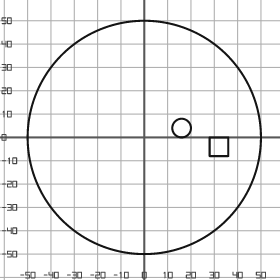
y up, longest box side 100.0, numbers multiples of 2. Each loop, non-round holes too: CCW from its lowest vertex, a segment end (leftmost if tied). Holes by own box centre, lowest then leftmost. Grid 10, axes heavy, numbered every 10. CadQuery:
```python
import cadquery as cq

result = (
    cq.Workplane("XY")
    .moveTo(0.0, 0.0)
    .circle(50.0)
    .moveTo(28.0, -8.0)
    .lineTo(36.0, -8.0)
    .lineTo(36.0, 0.0)
    .lineTo(28.0, 0.0)
    .close()
    .moveTo(16.0, 4.0)
    .circle(4.0)
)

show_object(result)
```